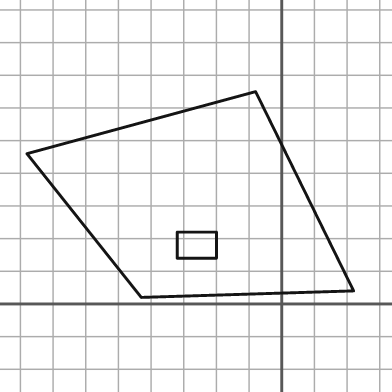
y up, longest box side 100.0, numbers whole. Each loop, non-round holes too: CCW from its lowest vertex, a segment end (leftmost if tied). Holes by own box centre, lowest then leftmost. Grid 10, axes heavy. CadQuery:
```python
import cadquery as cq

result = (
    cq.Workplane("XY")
    .moveTo(-43.0, 2.0)
    .lineTo(22.0, 4.0)
    .lineTo(-8.0, 65.0)
    .lineTo(-78.0, 46.0)
    .close()
    .moveTo(-32.0, 14.0)
    .lineTo(-20.0, 14.0)
    .lineTo(-20.0, 22.0)
    .lineTo(-32.0, 22.0)
    .close()
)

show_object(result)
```